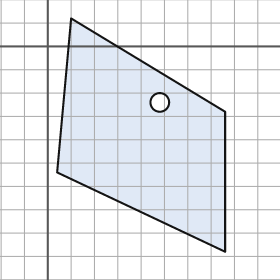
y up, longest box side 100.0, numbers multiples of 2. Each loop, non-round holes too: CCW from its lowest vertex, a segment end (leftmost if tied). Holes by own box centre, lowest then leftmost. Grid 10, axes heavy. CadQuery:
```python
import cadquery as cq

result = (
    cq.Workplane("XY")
    .moveTo(76.0, -88.0)
    .lineTo(76.0, -28.0)
    .lineTo(10.0, 12.0)
    .lineTo(4.0, -54.0)
    .close()
    .moveTo(48.0, -24.0)
    .circle(4.0)
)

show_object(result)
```